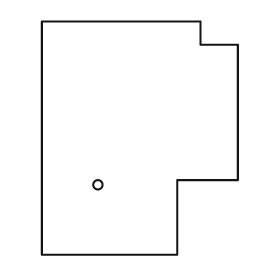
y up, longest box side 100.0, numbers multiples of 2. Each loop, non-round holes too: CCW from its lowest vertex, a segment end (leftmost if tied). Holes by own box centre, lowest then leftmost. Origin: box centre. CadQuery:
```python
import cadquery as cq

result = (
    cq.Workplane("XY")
    .moveTo(-42.0, -50.0)
    .lineTo(16.0, -50.0)
    .lineTo(16.0, -18.0)
    .lineTo(42.0, -18.0)
    .lineTo(42.0, 40.0)
    .lineTo(26.0, 40.0)
    .lineTo(26.0, 50.0)
    .lineTo(-42.0, 50.0)
    .close()
    .moveTo(-18.0, -20.0)
    .circle(2.0)
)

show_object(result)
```